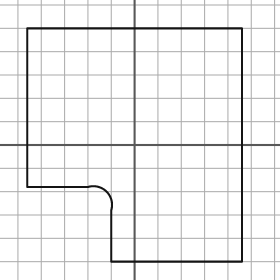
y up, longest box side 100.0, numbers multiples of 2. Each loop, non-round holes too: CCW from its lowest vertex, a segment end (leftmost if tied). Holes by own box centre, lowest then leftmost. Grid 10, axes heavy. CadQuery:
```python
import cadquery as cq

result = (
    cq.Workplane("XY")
    .moveTo(-10.0, -50.0)
    .lineTo(46.0, -50.0)
    .lineTo(46.0, 50.0)
    .lineTo(-46.0, 50.0)
    .lineTo(-46.0, -18.0)
    .lineTo(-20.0, -18.0)
    .threePointArc((-12.0, -20.0), (-10.0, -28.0))
    .close()
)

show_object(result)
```